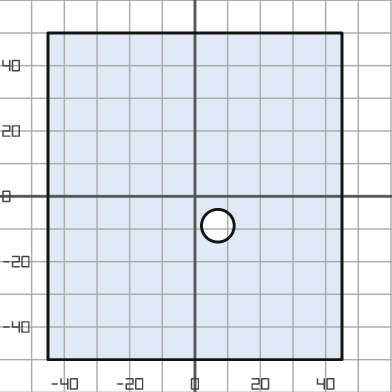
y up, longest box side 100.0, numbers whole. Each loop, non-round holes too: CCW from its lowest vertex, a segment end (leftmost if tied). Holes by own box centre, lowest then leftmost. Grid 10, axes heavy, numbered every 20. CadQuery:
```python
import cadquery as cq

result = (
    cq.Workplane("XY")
    .moveTo(-45.0, -50.0)
    .lineTo(45.0, -50.0)
    .lineTo(45.0, 50.0)
    .lineTo(-45.0, 50.0)
    .close()
    .moveTo(7.0, -9.0)
    .circle(5.0)
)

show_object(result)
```